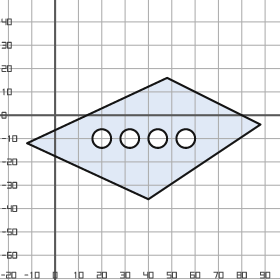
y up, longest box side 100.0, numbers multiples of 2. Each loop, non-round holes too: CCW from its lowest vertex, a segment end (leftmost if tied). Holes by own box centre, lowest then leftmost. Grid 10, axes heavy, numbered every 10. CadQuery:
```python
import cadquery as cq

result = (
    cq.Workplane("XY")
    .moveTo(40.0, -36.0)
    .lineTo(88.0, -4.0)
    .lineTo(48.0, 16.0)
    .lineTo(-12.0, -12.0)
    .close()
    .moveTo(20.0, -10.0)
    .circle(4.0)
    .moveTo(32.0, -10.0)
    .circle(4.0)
    .moveTo(44.0, -10.0)
    .circle(4.0)
    .moveTo(56.0, -10.0)
    .circle(4.0)
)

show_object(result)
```